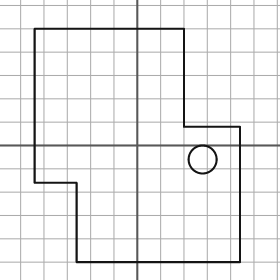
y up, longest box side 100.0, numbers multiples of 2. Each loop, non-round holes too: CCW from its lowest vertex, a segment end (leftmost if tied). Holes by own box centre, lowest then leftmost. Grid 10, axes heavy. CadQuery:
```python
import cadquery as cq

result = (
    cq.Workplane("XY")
    .moveTo(-26.0, -50.0)
    .lineTo(44.0, -50.0)
    .lineTo(44.0, 8.0)
    .lineTo(20.0, 8.0)
    .lineTo(20.0, 50.0)
    .lineTo(-44.0, 50.0)
    .lineTo(-44.0, -16.0)
    .lineTo(-26.0, -16.0)
    .close()
    .moveTo(28.0, -6.0)
    .circle(6.0)
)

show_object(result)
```